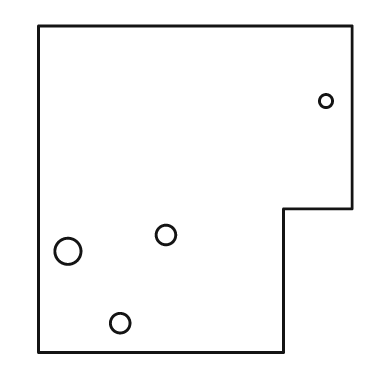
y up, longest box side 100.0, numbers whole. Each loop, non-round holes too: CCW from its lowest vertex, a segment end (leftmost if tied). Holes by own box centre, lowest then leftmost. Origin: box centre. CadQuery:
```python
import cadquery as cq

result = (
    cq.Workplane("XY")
    .moveTo(-48.0, -50.0)
    .lineTo(27.0, -50.0)
    .lineTo(27.0, -6.0)
    .lineTo(48.0, -6.0)
    .lineTo(48.0, 50.0)
    .lineTo(-48.0, 50.0)
    .close()
    .moveTo(-23.0, -41.0)
    .circle(3.0)
    .moveTo(-39.0, -19.0)
    .circle(4.0)
    .moveTo(-9.0, -14.0)
    .circle(3.0)
    .moveTo(40.0, 27.0)
    .circle(2.0)
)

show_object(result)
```